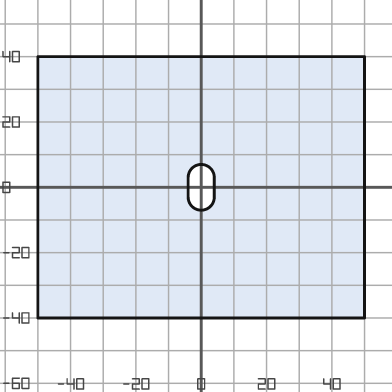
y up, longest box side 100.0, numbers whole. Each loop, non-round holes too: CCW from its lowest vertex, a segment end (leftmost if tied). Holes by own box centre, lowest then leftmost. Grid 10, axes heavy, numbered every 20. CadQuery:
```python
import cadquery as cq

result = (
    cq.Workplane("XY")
    .moveTo(-50.0, -40.0)
    .lineTo(50.0, -40.0)
    .lineTo(50.0, 40.0)
    .lineTo(-50.0, 40.0)
    .close()
    .moveTo(-4.0, -3.0)
    .threePointArc((0.0, -7.0), (4.0, -3.0))
    .lineTo(4.0, 3.0)
    .threePointArc((0.0, 7.0), (-4.0, 3.0))
    .close()
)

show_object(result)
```